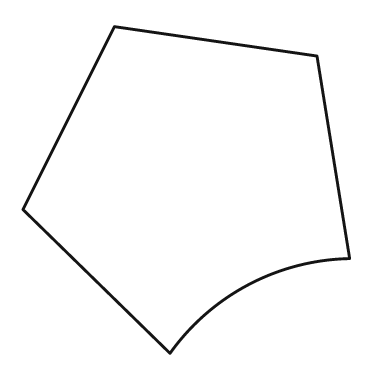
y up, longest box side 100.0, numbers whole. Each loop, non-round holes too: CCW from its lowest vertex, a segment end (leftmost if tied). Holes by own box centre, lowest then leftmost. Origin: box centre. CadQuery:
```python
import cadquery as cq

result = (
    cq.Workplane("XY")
    .moveTo(-5.0, -50.0)
    .threePointArc((19.0, -29.0), (50.0, -21.0))
    .lineTo(40.0, 41.0)
    .lineTo(-22.0, 50.0)
    .lineTo(-50.0, -6.0)
    .close()
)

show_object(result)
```